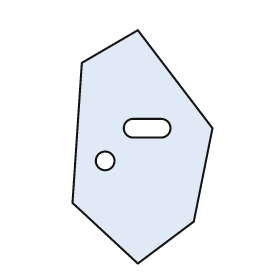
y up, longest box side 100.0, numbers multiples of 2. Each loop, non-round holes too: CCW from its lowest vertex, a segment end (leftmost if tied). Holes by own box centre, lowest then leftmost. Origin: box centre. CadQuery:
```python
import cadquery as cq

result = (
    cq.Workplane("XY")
    .moveTo(-2.0, -50.0)
    .lineTo(22.0, -32.0)
    .lineTo(30.0, 8.0)
    .lineTo(-2.0, 50.0)
    .lineTo(-26.0, 36.0)
    .lineTo(-30.0, -24.0)
    .close()
    .moveTo(-16.0, -6.0)
    .circle(4.0)
    .moveTo(-4.0, 4.0)
    .lineTo(8.0, 4.0)
    .threePointArc((12.0, 8.0), (8.0, 12.0))
    .lineTo(-4.0, 12.0)
    .threePointArc((-8.0, 8.0), (-4.0, 4.0))
    .close()
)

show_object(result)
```